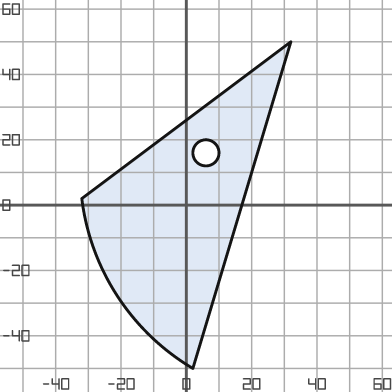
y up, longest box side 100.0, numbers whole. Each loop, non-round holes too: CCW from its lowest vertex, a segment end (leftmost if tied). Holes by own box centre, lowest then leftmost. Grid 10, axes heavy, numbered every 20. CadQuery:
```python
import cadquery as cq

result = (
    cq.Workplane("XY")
    .moveTo(2.0, -50.0)
    .lineTo(32.0, 50.0)
    .lineTo(-32.0, 2.0)
    .threePointArc((-21.0, -28.0), (2.0, -50.0))
    .close()
    .moveTo(6.0, 16.0)
    .circle(4.0)
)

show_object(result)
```